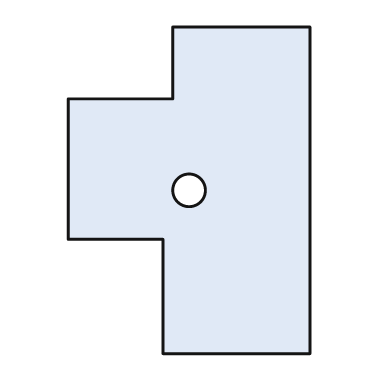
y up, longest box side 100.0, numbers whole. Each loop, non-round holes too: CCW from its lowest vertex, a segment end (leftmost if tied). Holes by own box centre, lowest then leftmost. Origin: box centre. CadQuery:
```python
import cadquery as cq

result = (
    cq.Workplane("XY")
    .moveTo(-8.0, -50.0)
    .lineTo(37.0, -50.0)
    .lineTo(37.0, 50.0)
    .lineTo(-5.0, 50.0)
    .lineTo(-5.0, 28.0)
    .lineTo(-37.0, 28.0)
    .lineTo(-37.0, -15.0)
    .lineTo(-8.0, -15.0)
    .close()
    .moveTo(0.0, 0.0)
    .circle(5.0)
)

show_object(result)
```